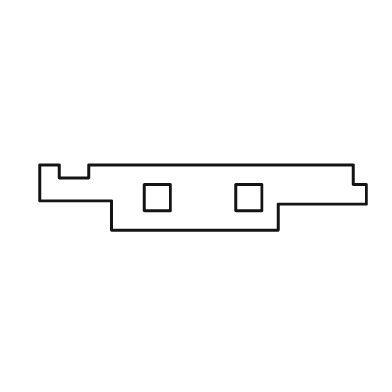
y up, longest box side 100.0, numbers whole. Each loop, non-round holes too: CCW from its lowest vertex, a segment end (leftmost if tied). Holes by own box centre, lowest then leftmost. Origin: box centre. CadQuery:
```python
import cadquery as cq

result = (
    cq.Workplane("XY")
    .moveTo(-28.0, -10.0)
    .lineTo(23.0, -10.0)
    .lineTo(23.0, -2.0)
    .lineTo(50.0, -2.0)
    .lineTo(50.0, 4.0)
    .lineTo(46.0, 4.0)
    .lineTo(46.0, 10.0)
    .lineTo(-35.0, 10.0)
    .lineTo(-35.0, 6.0)
    .lineTo(-44.0, 6.0)
    .lineTo(-44.0, 10.0)
    .lineTo(-50.0, 10.0)
    .lineTo(-50.0, -1.0)
    .lineTo(-28.0, -1.0)
    .close()
    .moveTo(-18.0, -4.0)
    .lineTo(-10.0, -4.0)
    .lineTo(-10.0, 4.0)
    .lineTo(-18.0, 4.0)
    .close()
    .moveTo(10.0, -4.0)
    .lineTo(18.0, -4.0)
    .lineTo(18.0, 4.0)
    .lineTo(10.0, 4.0)
    .close()
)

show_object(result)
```